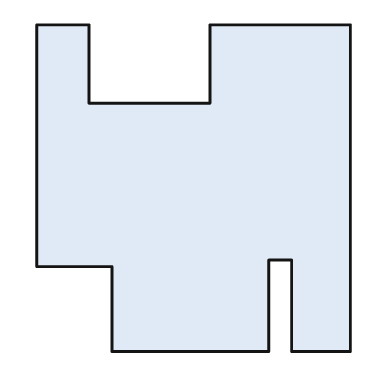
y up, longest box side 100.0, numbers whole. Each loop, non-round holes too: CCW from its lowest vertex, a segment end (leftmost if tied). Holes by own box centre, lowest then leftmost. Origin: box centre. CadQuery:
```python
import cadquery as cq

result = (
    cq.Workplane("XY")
    .moveTo(-25.0, -50.0)
    .lineTo(23.0, -50.0)
    .lineTo(23.0, -22.0)
    .lineTo(30.0, -22.0)
    .lineTo(30.0, -50.0)
    .lineTo(48.0, -50.0)
    .lineTo(48.0, 50.0)
    .lineTo(5.0, 50.0)
    .lineTo(5.0, 26.0)
    .lineTo(-32.0, 26.0)
    .lineTo(-32.0, 50.0)
    .lineTo(-48.0, 50.0)
    .lineTo(-48.0, -24.0)
    .lineTo(-25.0, -24.0)
    .close()
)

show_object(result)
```